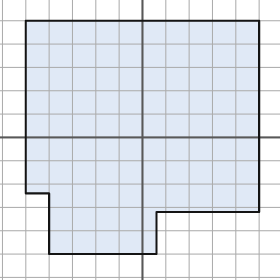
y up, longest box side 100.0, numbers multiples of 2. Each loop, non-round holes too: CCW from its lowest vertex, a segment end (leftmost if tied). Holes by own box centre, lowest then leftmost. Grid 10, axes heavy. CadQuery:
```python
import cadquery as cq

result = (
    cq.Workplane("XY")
    .moveTo(-40.0, -50.0)
    .lineTo(6.0, -50.0)
    .lineTo(6.0, -32.0)
    .lineTo(50.0, -32.0)
    .lineTo(50.0, 50.0)
    .lineTo(-50.0, 50.0)
    .lineTo(-50.0, -24.0)
    .lineTo(-40.0, -24.0)
    .close()
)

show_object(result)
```